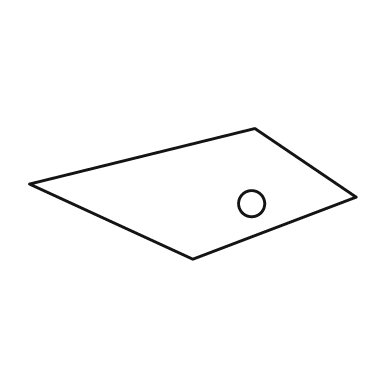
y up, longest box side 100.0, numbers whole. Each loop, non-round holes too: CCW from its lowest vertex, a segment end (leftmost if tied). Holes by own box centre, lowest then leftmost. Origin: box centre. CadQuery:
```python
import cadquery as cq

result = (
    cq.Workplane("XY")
    .moveTo(0.0, -20.0)
    .lineTo(50.0, -1.0)
    .lineTo(19.0, 20.0)
    .lineTo(-50.0, 3.0)
    .close()
    .moveTo(18.0, -3.0)
    .circle(4.0)
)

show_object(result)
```